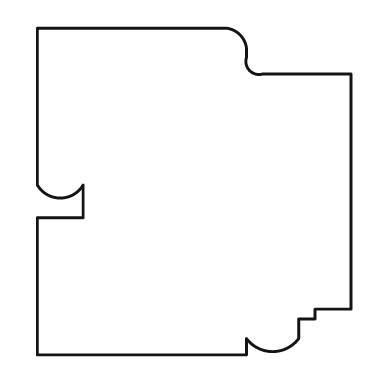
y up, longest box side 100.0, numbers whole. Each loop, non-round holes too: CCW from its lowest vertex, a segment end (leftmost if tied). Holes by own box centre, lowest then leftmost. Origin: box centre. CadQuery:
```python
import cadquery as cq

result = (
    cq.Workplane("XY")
    .moveTo(-48.0, -50.0)
    .lineTo(16.0, -50.0)
    .lineTo(16.0, -45.0)
    .threePointArc((24.0, -49.0), (32.0, -45.0))
    .lineTo(32.0, -39.0)
    .lineTo(37.0, -39.0)
    .lineTo(37.0, -36.0)
    .lineTo(48.0, -36.0)
    .lineTo(48.0, 36.0)
    .lineTo(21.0, 36.0)
    .threePointArc((17.0, 37.0), (16.0, 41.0))
    .lineTo(16.0, 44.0)
    .threePointArc((14.0, 48.0), (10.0, 50.0))
    .lineTo(-48.0, 50.0)
    .lineTo(-48.0, 2.0)
    .threePointArc((-41.0, -2.0), (-34.0, 2.0))
    .lineTo(-34.0, -8.0)
    .lineTo(-48.0, -8.0)
    .close()
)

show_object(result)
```